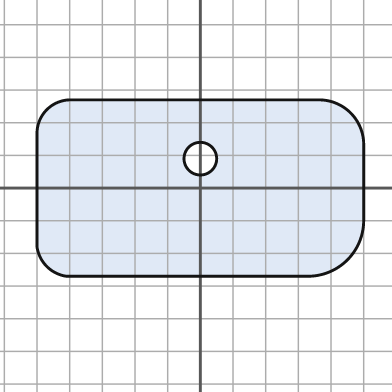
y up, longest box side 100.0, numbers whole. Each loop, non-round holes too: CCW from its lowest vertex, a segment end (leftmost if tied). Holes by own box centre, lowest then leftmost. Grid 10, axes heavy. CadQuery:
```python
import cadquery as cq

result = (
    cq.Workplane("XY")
    .moveTo(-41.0, -27.0)
    .lineTo(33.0, -27.0)
    .threePointArc((45.0, -22.0), (50.0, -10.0))
    .lineTo(50.0, 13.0)
    .threePointArc((46.0, 23.0), (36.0, 27.0))
    .lineTo(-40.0, 27.0)
    .threePointArc((-47.0, 24.0), (-50.0, 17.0))
    .lineTo(-50.0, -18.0)
    .threePointArc((-47.0, -24.0), (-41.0, -27.0))
    .close()
    .moveTo(0.0, 9.0)
    .circle(5.0)
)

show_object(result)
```